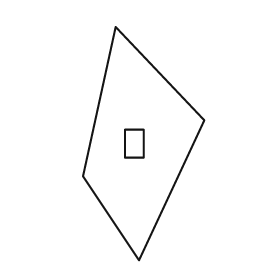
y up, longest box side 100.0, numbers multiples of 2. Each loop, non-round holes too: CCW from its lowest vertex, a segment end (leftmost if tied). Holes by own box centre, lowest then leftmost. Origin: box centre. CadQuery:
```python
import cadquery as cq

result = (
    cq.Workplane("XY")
    .moveTo(-2.0, -50.0)
    .lineTo(26.0, 10.0)
    .lineTo(-12.0, 50.0)
    .lineTo(-26.0, -14.0)
    .close()
    .moveTo(-8.0, -6.0)
    .lineTo(0.0, -6.0)
    .lineTo(0.0, 6.0)
    .lineTo(-8.0, 6.0)
    .close()
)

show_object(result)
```